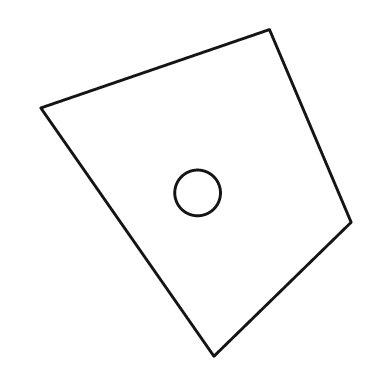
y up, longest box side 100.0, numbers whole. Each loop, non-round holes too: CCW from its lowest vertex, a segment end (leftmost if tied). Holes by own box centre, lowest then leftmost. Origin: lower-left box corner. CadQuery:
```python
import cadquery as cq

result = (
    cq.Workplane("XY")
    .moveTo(53.0, 0.0)
    .lineTo(95.0, 41.0)
    .lineTo(70.0, 100.0)
    .lineTo(0.0, 76.0)
    .close()
    .moveTo(48.0, 50.0)
    .circle(7.0)
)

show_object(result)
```